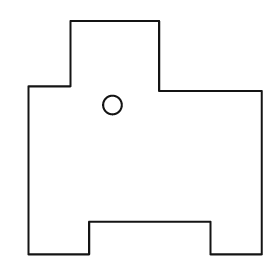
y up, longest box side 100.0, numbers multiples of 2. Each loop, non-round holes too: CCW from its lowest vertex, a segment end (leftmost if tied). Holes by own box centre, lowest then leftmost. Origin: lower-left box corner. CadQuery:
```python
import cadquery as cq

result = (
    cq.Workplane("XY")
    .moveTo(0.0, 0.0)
    .lineTo(26.0, 0.0)
    .lineTo(26.0, 14.0)
    .lineTo(78.0, 14.0)
    .lineTo(78.0, 0.0)
    .lineTo(100.0, 0.0)
    .lineTo(100.0, 70.0)
    .lineTo(56.0, 70.0)
    .lineTo(56.0, 100.0)
    .lineTo(18.0, 100.0)
    .lineTo(18.0, 72.0)
    .lineTo(0.0, 72.0)
    .close()
    .moveTo(36.0, 64.0)
    .circle(4.0)
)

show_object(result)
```